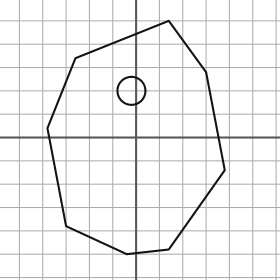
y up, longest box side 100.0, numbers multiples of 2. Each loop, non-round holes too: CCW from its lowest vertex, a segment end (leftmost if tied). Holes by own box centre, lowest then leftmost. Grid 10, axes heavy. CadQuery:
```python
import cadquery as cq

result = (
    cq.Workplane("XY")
    .moveTo(-4.0, -50.0)
    .lineTo(14.0, -48.0)
    .lineTo(38.0, -14.0)
    .lineTo(30.0, 28.0)
    .lineTo(14.0, 50.0)
    .lineTo(-26.0, 34.0)
    .lineTo(-38.0, 4.0)
    .lineTo(-30.0, -38.0)
    .close()
    .moveTo(-2.0, 20.0)
    .circle(6.0)
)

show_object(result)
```